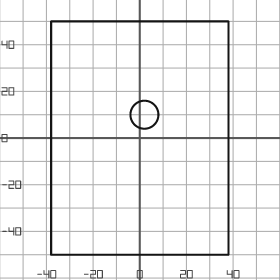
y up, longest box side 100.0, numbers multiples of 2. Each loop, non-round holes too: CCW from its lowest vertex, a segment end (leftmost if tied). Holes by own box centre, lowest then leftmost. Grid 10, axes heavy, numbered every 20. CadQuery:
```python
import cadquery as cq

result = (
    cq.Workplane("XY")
    .moveTo(-38.0, -50.0)
    .lineTo(38.0, -50.0)
    .lineTo(38.0, 50.0)
    .lineTo(-38.0, 50.0)
    .close()
    .moveTo(2.0, 10.0)
    .circle(6.0)
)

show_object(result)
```